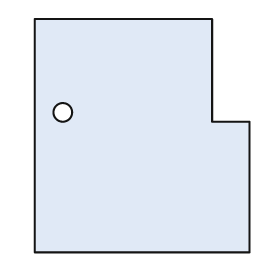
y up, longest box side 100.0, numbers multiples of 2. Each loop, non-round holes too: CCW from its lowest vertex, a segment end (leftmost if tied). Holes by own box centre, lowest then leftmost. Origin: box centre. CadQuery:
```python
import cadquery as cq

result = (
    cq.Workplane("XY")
    .moveTo(-46.0, -50.0)
    .lineTo(46.0, -50.0)
    .lineTo(46.0, 6.0)
    .lineTo(30.0, 6.0)
    .lineTo(30.0, 50.0)
    .lineTo(-46.0, 50.0)
    .close()
    .moveTo(-34.0, 10.0)
    .circle(4.0)
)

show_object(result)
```